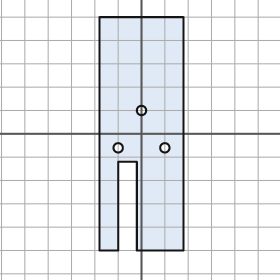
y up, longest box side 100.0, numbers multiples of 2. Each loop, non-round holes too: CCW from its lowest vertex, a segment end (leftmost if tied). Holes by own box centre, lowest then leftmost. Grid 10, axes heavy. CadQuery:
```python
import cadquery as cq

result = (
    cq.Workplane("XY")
    .moveTo(-18.0, -50.0)
    .lineTo(-10.0, -50.0)
    .lineTo(-10.0, -12.0)
    .lineTo(-2.0, -12.0)
    .lineTo(-2.0, -50.0)
    .lineTo(18.0, -50.0)
    .lineTo(18.0, 50.0)
    .lineTo(-18.0, 50.0)
    .close()
    .moveTo(-10.0, -6.0)
    .circle(2.0)
    .moveTo(10.0, -6.0)
    .circle(2.0)
    .moveTo(0.0, 10.0)
    .circle(2.0)
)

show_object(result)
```